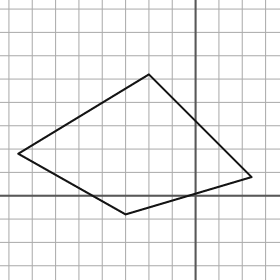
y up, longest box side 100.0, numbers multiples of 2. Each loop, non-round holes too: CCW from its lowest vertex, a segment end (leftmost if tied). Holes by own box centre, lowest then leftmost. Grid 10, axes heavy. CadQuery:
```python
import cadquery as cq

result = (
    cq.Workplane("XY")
    .moveTo(-30.0, -8.0)
    .lineTo(24.0, 8.0)
    .lineTo(-20.0, 52.0)
    .lineTo(-76.0, 18.0)
    .close()
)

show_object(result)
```